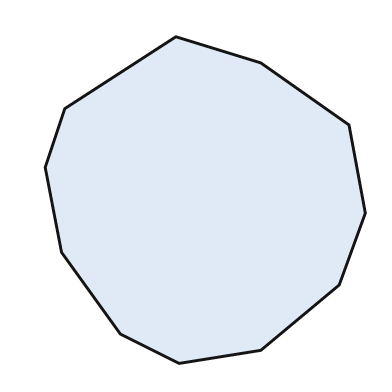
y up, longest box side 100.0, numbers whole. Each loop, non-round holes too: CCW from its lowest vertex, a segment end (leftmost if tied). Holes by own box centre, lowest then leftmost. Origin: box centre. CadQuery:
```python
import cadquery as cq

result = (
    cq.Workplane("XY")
    .moveTo(-8.0, -50.0)
    .lineTo(17.0, -46.0)
    .lineTo(41.0, -26.0)
    .lineTo(49.0, -4.0)
    .lineTo(44.0, 23.0)
    .lineTo(17.0, 42.0)
    .lineTo(-9.0, 50.0)
    .lineTo(-43.0, 28.0)
    .lineTo(-49.0, 10.0)
    .lineTo(-44.0, -16.0)
    .lineTo(-26.0, -41.0)
    .close()
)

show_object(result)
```